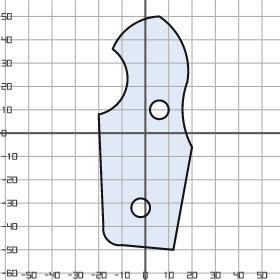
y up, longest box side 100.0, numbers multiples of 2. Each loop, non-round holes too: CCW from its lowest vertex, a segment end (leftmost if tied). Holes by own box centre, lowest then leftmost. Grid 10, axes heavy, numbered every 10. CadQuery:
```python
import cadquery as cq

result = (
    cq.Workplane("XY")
    .moveTo(12.0, -50.0)
    .lineTo(20.0, -6.0)
    .threePointArc((16.0, 8.0), (18.0, 22.0))
    .threePointArc((16.0, 38.0), (6.0, 50.0))
    .threePointArc((-6.0, 46.0), (-14.0, 36.0))
    .threePointArc((-8.0, 20.0), (-20.0, 8.0))
    .lineTo(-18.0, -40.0)
    .threePointArc((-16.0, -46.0), (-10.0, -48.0))
    .close()
    .moveTo(-2.0, -32.0)
    .circle(4.0)
    .moveTo(6.0, 10.0)
    .circle(4.0)
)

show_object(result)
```